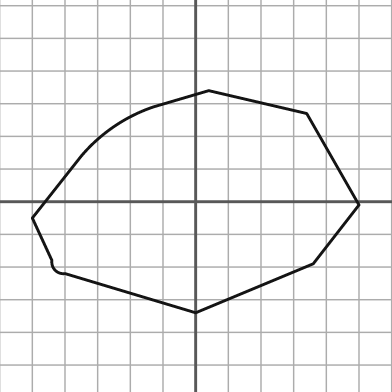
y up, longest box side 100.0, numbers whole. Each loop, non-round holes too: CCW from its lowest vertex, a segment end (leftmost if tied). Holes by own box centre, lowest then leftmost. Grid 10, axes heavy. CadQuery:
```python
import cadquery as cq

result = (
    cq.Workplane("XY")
    .moveTo(0.0, -34.0)
    .lineTo(36.0, -19.0)
    .lineTo(50.0, -1.0)
    .lineTo(34.0, 27.0)
    .lineTo(4.0, 34.0)
    .lineTo(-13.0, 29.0)
    .threePointArc((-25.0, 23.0), (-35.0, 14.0))
    .lineTo(-50.0, -5.0)
    .lineTo(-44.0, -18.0)
    .threePointArc((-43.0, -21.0), (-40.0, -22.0))
    .close()
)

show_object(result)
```